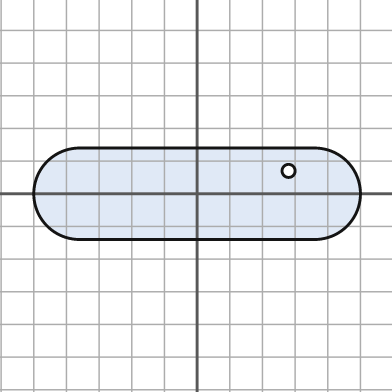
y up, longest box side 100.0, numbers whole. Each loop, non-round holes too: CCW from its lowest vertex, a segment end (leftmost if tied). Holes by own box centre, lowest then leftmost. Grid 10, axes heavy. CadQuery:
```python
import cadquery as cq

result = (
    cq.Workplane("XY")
    .moveTo(-36.0, -14.0)
    .lineTo(36.0, -14.0)
    .threePointArc((50.0, 0.0), (36.0, 14.0))
    .lineTo(-36.0, 14.0)
    .threePointArc((-50.0, 0.0), (-36.0, -14.0))
    .close()
    .moveTo(28.0, 7.0)
    .circle(2.0)
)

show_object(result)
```